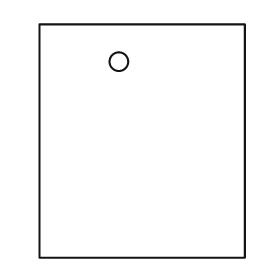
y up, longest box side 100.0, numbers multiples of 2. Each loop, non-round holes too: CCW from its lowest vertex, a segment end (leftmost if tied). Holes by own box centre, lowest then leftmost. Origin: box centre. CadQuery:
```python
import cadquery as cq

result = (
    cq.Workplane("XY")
    .moveTo(-44.0, -50.0)
    .lineTo(44.0, -50.0)
    .lineTo(44.0, 50.0)
    .lineTo(-44.0, 50.0)
    .close()
    .moveTo(-10.0, 34.0)
    .circle(4.0)
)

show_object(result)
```